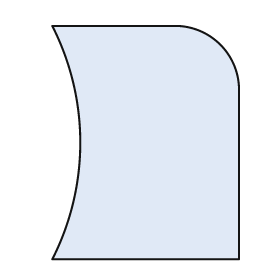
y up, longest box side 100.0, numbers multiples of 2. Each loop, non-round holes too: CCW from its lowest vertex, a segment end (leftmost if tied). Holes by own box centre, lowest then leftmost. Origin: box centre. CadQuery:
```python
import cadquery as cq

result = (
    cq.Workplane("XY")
    .moveTo(-40.0, -50.0)
    .lineTo(40.0, -50.0)
    .lineTo(40.0, 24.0)
    .threePointArc((32.0, 42.0), (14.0, 50.0))
    .lineTo(-40.0, 50.0)
    .threePointArc((-28.0, 0.0), (-40.0, -50.0))
    .close()
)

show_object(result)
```